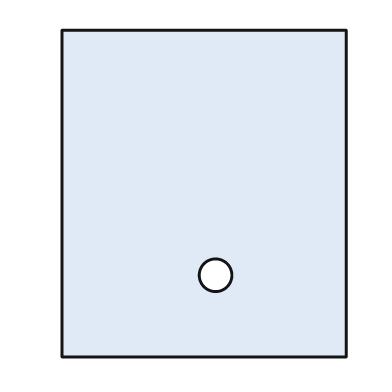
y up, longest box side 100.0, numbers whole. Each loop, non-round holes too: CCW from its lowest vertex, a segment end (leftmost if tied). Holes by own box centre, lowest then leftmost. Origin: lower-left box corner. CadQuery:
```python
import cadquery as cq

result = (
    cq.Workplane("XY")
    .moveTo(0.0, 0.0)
    .lineTo(87.0, 0.0)
    .lineTo(87.0, 100.0)
    .lineTo(0.0, 100.0)
    .close()
    .moveTo(47.0, 25.0)
    .circle(5.0)
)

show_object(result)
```